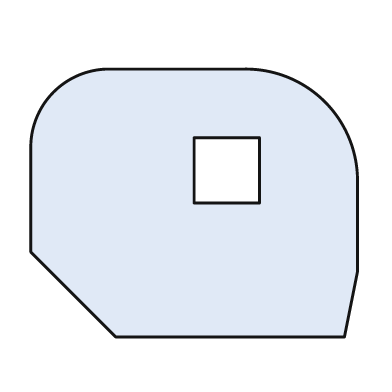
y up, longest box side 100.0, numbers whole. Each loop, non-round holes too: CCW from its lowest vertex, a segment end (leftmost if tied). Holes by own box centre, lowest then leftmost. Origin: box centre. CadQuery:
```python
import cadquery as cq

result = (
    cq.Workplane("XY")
    .moveTo(-24.0, -41.0)
    .lineTo(46.0, -41.0)
    .lineTo(50.0, -21.0)
    .lineTo(50.0, 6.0)
    .threePointArc((40.0, 31.0), (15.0, 41.0))
    .lineTo(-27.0, 41.0)
    .threePointArc((-43.0, 34.0), (-50.0, 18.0))
    .lineTo(-50.0, -15.0)
    .close()
    .moveTo(0.0, 0.0)
    .lineTo(20.0, 0.0)
    .lineTo(20.0, 20.0)
    .lineTo(0.0, 20.0)
    .close()
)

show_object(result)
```